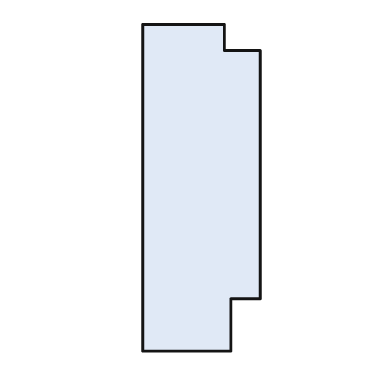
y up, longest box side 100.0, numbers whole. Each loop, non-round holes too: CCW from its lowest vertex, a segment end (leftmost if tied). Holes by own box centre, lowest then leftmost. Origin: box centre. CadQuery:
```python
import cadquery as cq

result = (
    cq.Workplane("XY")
    .moveTo(-18.0, -50.0)
    .lineTo(9.0, -50.0)
    .lineTo(9.0, -34.0)
    .lineTo(18.0, -34.0)
    .lineTo(18.0, 42.0)
    .lineTo(7.0, 42.0)
    .lineTo(7.0, 50.0)
    .lineTo(-18.0, 50.0)
    .close()
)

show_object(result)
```